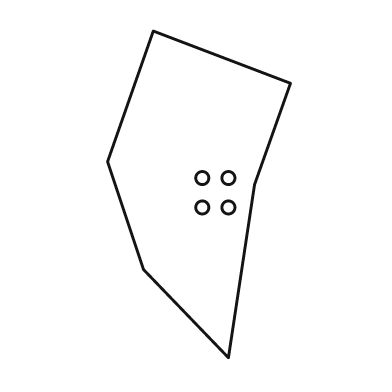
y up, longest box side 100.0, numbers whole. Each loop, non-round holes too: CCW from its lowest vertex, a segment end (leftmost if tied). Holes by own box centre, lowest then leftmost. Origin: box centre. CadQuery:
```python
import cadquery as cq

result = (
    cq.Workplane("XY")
    .moveTo(9.0, -50.0)
    .lineTo(17.0, 3.0)
    .lineTo(28.0, 34.0)
    .lineTo(-14.0, 50.0)
    .lineTo(-28.0, 10.0)
    .lineTo(-17.0, -23.0)
    .close()
    .moveTo(1.0, -4.0)
    .circle(2.0)
    .moveTo(9.0, -4.0)
    .circle(2.0)
    .moveTo(1.0, 5.0)
    .circle(2.0)
    .moveTo(9.0, 5.0)
    .circle(2.0)
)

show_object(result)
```